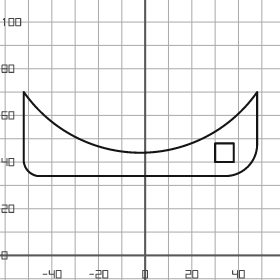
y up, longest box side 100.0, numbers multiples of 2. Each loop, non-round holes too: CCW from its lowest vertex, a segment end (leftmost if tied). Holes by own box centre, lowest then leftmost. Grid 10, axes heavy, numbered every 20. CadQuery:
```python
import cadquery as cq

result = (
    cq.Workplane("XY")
    .moveTo(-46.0, 34.0)
    .lineTo(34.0, 34.0)
    .threePointArc((44.0, 38.0), (48.0, 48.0))
    .lineTo(48.0, 70.0)
    .threePointArc((-2.0, 44.0), (-52.0, 70.0))
    .lineTo(-52.0, 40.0)
    .threePointArc((-50.0, 36.0), (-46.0, 34.0))
    .close()
    .moveTo(30.0, 40.0)
    .lineTo(38.0, 40.0)
    .lineTo(38.0, 48.0)
    .lineTo(30.0, 48.0)
    .close()
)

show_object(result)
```